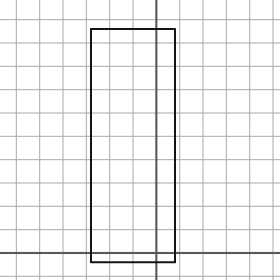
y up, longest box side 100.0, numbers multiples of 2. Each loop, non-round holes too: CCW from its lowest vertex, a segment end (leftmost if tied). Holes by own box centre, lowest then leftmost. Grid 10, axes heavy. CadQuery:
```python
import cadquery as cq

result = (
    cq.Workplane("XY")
    .moveTo(-28.0, -4.0)
    .lineTo(8.0, -4.0)
    .lineTo(8.0, 96.0)
    .lineTo(-28.0, 96.0)
    .close()
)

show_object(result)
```